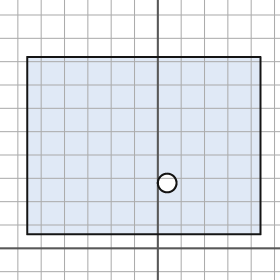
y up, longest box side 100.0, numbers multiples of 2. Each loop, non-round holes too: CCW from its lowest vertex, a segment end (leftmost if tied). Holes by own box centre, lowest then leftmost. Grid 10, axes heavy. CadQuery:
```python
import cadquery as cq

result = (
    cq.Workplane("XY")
    .moveTo(-56.0, 6.0)
    .lineTo(44.0, 6.0)
    .lineTo(44.0, 82.0)
    .lineTo(-56.0, 82.0)
    .close()
    .moveTo(4.0, 28.0)
    .circle(4.0)
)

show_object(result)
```